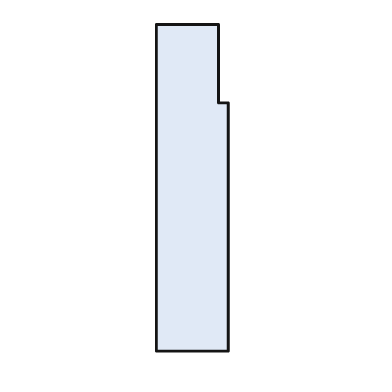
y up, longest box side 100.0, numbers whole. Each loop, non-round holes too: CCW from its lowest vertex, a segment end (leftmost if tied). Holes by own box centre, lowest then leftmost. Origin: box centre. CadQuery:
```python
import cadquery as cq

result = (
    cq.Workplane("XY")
    .moveTo(-11.0, -50.0)
    .lineTo(11.0, -50.0)
    .lineTo(11.0, 26.0)
    .lineTo(8.0, 26.0)
    .lineTo(8.0, 50.0)
    .lineTo(-11.0, 50.0)
    .close()
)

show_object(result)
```